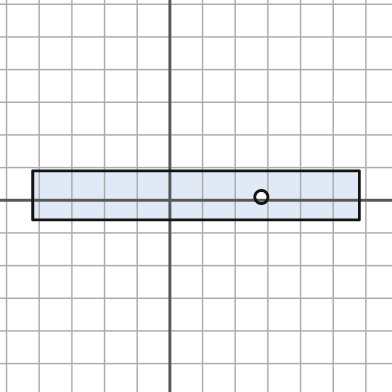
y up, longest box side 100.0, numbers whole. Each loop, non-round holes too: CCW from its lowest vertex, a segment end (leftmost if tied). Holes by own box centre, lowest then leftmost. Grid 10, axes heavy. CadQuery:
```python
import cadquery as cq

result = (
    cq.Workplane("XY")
    .moveTo(-42.0, -6.0)
    .lineTo(58.0, -6.0)
    .lineTo(58.0, 9.0)
    .lineTo(-42.0, 9.0)
    .close()
    .moveTo(28.0, 1.0)
    .circle(2.0)
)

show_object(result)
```